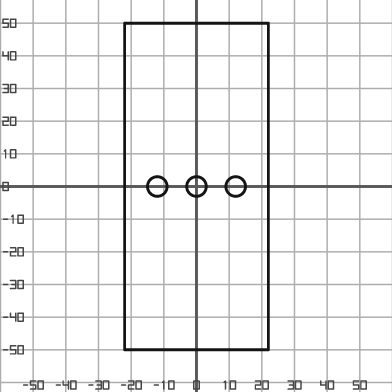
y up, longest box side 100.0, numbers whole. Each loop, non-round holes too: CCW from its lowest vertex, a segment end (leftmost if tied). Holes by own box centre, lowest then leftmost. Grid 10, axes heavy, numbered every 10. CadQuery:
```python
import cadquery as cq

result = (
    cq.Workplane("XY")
    .moveTo(-22.0, -50.0)
    .lineTo(22.0, -50.0)
    .lineTo(22.0, 50.0)
    .lineTo(-22.0, 50.0)
    .close()
    .moveTo(-12.0, 0.0)
    .circle(3.0)
    .moveTo(0.0, 0.0)
    .circle(3.0)
    .moveTo(12.0, 0.0)
    .circle(3.0)
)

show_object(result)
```